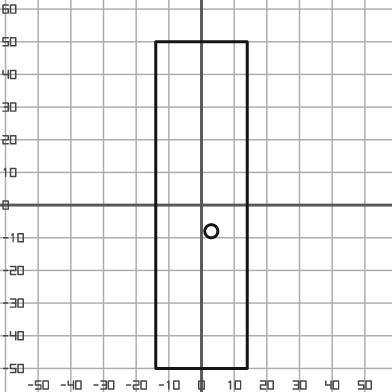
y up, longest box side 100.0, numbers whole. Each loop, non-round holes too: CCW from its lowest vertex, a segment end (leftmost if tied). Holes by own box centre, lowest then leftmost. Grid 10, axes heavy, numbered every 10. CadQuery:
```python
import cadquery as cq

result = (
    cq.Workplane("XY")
    .moveTo(-14.0, -50.0)
    .lineTo(14.0, -50.0)
    .lineTo(14.0, 50.0)
    .lineTo(-14.0, 50.0)
    .close()
    .moveTo(3.0, -8.0)
    .circle(2.0)
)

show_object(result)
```